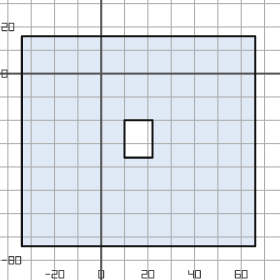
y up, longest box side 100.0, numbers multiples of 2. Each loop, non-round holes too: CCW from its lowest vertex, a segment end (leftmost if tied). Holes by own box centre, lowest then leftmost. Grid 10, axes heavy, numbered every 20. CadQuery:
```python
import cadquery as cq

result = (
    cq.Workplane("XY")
    .moveTo(-34.0, -74.0)
    .lineTo(66.0, -74.0)
    .lineTo(66.0, 16.0)
    .lineTo(-34.0, 16.0)
    .close()
    .moveTo(10.0, -36.0)
    .lineTo(22.0, -36.0)
    .lineTo(22.0, -20.0)
    .lineTo(10.0, -20.0)
    .close()
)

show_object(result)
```